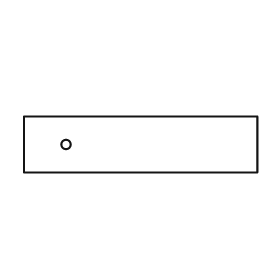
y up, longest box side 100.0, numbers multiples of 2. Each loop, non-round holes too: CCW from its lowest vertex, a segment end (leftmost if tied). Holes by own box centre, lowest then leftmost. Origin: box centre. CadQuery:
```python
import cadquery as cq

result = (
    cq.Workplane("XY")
    .moveTo(-50.0, -12.0)
    .lineTo(50.0, -12.0)
    .lineTo(50.0, 12.0)
    .lineTo(-50.0, 12.0)
    .close()
    .moveTo(-32.0, 0.0)
    .circle(2.0)
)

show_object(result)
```